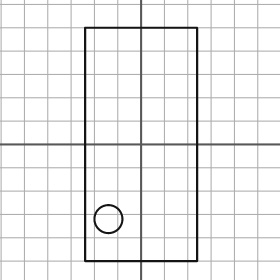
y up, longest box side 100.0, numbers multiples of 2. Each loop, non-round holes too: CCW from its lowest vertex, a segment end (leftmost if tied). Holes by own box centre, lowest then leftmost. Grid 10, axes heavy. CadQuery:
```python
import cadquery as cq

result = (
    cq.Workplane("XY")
    .moveTo(-24.0, -50.0)
    .lineTo(24.0, -50.0)
    .lineTo(24.0, 50.0)
    .lineTo(-24.0, 50.0)
    .close()
    .moveTo(-14.0, -32.0)
    .circle(6.0)
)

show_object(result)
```